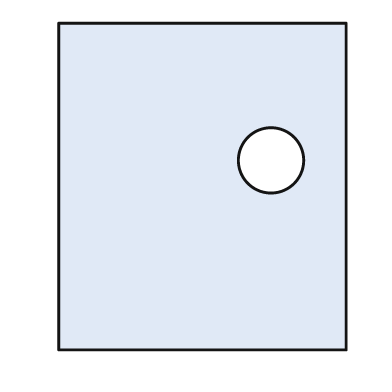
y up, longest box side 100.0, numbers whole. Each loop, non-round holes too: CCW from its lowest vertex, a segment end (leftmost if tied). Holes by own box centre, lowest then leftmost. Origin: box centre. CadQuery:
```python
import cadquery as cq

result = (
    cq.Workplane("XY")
    .moveTo(-44.0, -50.0)
    .lineTo(44.0, -50.0)
    .lineTo(44.0, 50.0)
    .lineTo(-44.0, 50.0)
    .close()
    .moveTo(21.0, 8.0)
    .circle(10.0)
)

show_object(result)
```